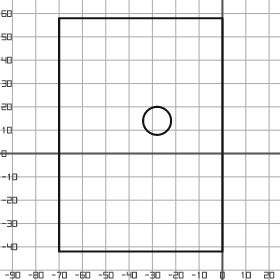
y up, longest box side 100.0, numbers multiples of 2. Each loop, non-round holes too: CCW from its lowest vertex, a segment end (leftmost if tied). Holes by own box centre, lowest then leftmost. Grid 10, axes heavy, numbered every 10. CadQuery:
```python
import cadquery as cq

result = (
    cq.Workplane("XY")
    .moveTo(-70.0, -42.0)
    .lineTo(0.0, -42.0)
    .lineTo(0.0, 58.0)
    .lineTo(-70.0, 58.0)
    .close()
    .moveTo(-28.0, 14.0)
    .circle(6.0)
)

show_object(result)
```